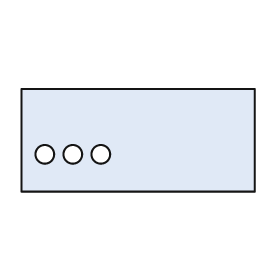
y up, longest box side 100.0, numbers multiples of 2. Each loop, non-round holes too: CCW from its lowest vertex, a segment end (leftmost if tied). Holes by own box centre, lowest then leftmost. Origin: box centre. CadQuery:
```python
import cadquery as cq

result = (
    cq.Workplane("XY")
    .moveTo(-50.0, -22.0)
    .lineTo(50.0, -22.0)
    .lineTo(50.0, 22.0)
    .lineTo(-50.0, 22.0)
    .close()
    .moveTo(-40.0, -6.0)
    .circle(4.0)
    .moveTo(-28.0, -6.0)
    .circle(4.0)
    .moveTo(-16.0, -6.0)
    .circle(4.0)
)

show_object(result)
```